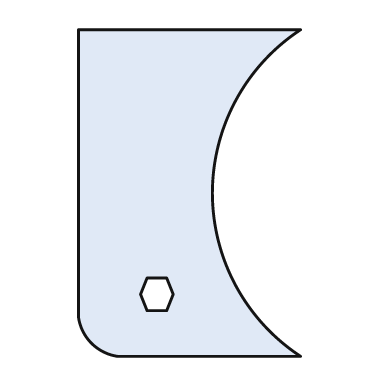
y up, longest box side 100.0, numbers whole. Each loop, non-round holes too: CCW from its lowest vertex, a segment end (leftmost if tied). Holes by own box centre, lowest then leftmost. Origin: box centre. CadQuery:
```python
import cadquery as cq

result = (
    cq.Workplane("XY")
    .moveTo(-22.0, -50.0)
    .lineTo(34.0, -50.0)
    .threePointArc((7.0, 0.0), (34.0, 50.0))
    .lineTo(-34.0, 50.0)
    .lineTo(-34.0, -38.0)
    .threePointArc((-30.0, -46.0), (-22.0, -50.0))
    .close()
    .moveTo(-13.0, -36.0)
    .lineTo(-7.0, -36.0)
    .lineTo(-5.0, -31.0)
    .lineTo(-7.0, -26.0)
    .lineTo(-13.0, -26.0)
    .lineTo(-15.0, -31.0)
    .close()
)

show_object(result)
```